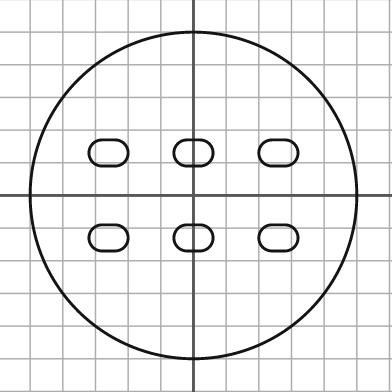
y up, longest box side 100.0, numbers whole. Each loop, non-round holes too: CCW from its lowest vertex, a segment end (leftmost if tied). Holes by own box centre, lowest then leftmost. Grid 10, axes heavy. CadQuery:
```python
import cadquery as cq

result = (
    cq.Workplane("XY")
    .moveTo(0.0, 0.0)
    .circle(50.0)
    .moveTo(-28.0, -17.0)
    .lineTo(-24.0, -17.0)
    .threePointArc((-20.0, -13.0), (-24.0, -9.0))
    .lineTo(-28.0, -9.0)
    .threePointArc((-32.0, -13.0), (-28.0, -17.0))
    .close()
    .moveTo(-2.0, -17.0)
    .lineTo(2.0, -17.0)
    .threePointArc((6.0, -13.0), (2.0, -9.0))
    .lineTo(-2.0, -9.0)
    .threePointArc((-6.0, -13.0), (-2.0, -17.0))
    .close()
    .moveTo(24.0, -17.0)
    .lineTo(28.0, -17.0)
    .threePointArc((32.0, -13.0), (28.0, -9.0))
    .lineTo(24.0, -9.0)
    .threePointArc((20.0, -13.0), (24.0, -17.0))
    .close()
    .moveTo(-28.0, 9.0)
    .lineTo(-24.0, 9.0)
    .threePointArc((-20.0, 13.0), (-24.0, 17.0))
    .lineTo(-28.0, 17.0)
    .threePointArc((-32.0, 13.0), (-28.0, 9.0))
    .close()
    .moveTo(-2.0, 9.0)
    .lineTo(2.0, 9.0)
    .threePointArc((6.0, 13.0), (2.0, 17.0))
    .lineTo(-2.0, 17.0)
    .threePointArc((-6.0, 13.0), (-2.0, 9.0))
    .close()
    .moveTo(24.0, 9.0)
    .lineTo(28.0, 9.0)
    .threePointArc((32.0, 13.0), (28.0, 17.0))
    .lineTo(24.0, 17.0)
    .threePointArc((20.0, 13.0), (24.0, 9.0))
    .close()
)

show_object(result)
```